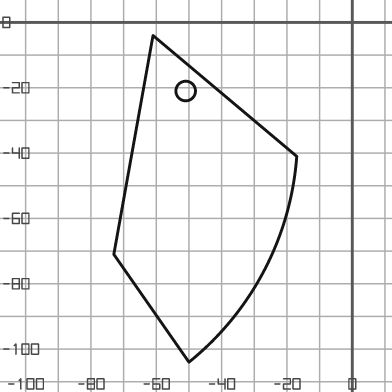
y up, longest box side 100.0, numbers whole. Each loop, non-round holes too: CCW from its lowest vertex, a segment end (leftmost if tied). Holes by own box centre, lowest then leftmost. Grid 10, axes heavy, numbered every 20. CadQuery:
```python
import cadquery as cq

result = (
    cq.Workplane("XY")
    .moveTo(-50.0, -104.0)
    .threePointArc((-27.0, -76.0), (-17.0, -41.0))
    .lineTo(-61.0, -4.0)
    .lineTo(-73.0, -71.0)
    .close()
    .moveTo(-51.0, -21.0)
    .circle(3.0)
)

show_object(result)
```